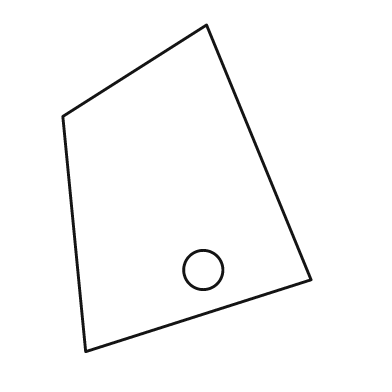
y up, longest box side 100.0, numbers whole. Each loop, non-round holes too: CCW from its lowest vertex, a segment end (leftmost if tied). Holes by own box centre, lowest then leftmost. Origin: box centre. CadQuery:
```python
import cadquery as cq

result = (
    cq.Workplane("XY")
    .moveTo(-31.0, -50.0)
    .lineTo(38.0, -28.0)
    .lineTo(6.0, 50.0)
    .lineTo(-38.0, 22.0)
    .close()
    .moveTo(5.0, -25.0)
    .circle(6.0)
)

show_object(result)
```